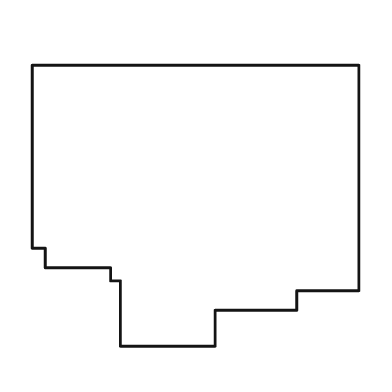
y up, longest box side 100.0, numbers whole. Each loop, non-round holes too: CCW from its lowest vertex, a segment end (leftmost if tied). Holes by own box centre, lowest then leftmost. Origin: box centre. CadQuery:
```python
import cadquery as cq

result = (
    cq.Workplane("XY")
    .moveTo(-23.0, -43.0)
    .lineTo(6.0, -43.0)
    .lineTo(6.0, -32.0)
    .lineTo(31.0, -32.0)
    .lineTo(31.0, -26.0)
    .lineTo(50.0, -26.0)
    .lineTo(50.0, 43.0)
    .lineTo(-50.0, 43.0)
    .lineTo(-50.0, -13.0)
    .lineTo(-46.0, -13.0)
    .lineTo(-46.0, -19.0)
    .lineTo(-26.0, -19.0)
    .lineTo(-26.0, -23.0)
    .lineTo(-23.0, -23.0)
    .close()
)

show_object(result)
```